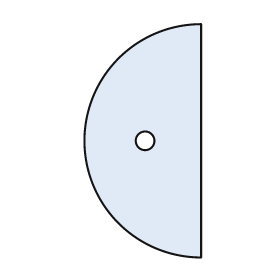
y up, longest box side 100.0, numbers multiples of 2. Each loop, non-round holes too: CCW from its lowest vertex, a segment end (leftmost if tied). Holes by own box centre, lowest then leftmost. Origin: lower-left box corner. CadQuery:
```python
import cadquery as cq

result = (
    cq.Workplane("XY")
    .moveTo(50.0, 0.0)
    .lineTo(50.0, 100.0)
    .threePointArc((0.0, 50.0), (50.0, 0.0))
    .close()
    .moveTo(26.0, 50.0)
    .circle(4.0)
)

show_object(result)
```